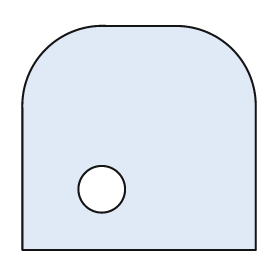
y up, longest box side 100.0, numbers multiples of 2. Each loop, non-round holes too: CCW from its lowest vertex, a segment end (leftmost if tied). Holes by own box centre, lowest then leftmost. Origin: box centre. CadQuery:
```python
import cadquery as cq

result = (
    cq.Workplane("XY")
    .moveTo(-50.0, -48.0)
    .lineTo(50.0, -48.0)
    .lineTo(50.0, 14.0)
    .threePointArc((40.0, 38.0), (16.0, 48.0))
    .lineTo(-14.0, 48.0)
    .threePointArc((-40.0, 38.0), (-50.0, 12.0))
    .close()
    .moveTo(-16.0, -22.0)
    .circle(10.0)
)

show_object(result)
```